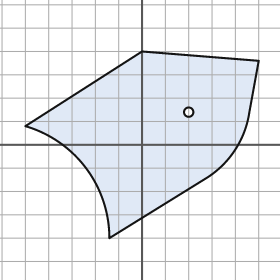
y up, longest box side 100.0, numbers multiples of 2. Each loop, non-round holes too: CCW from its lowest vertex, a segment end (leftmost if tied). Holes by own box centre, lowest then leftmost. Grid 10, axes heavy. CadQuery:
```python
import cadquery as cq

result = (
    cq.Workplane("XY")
    .moveTo(-14.0, -40.0)
    .lineTo(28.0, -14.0)
    .threePointArc((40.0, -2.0), (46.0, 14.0))
    .lineTo(50.0, 36.0)
    .lineTo(0.0, 40.0)
    .lineTo(-50.0, 8.0)
    .threePointArc((-24.0, -10.0), (-14.0, -40.0))
    .close()
    .moveTo(20.0, 14.0)
    .circle(2.0)
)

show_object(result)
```